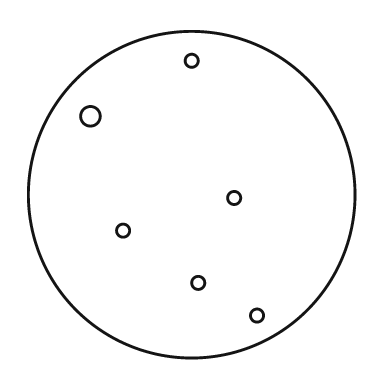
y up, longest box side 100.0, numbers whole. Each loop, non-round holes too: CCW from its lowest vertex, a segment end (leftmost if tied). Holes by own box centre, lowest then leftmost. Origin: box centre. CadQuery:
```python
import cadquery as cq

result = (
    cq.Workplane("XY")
    .moveTo(0.0, 0.0)
    .circle(50.0)
    .moveTo(20.0, -37.0)
    .circle(2.0)
    .moveTo(2.0, -27.0)
    .circle(2.0)
    .moveTo(-21.0, -11.0)
    .circle(2.0)
    .moveTo(13.0, -1.0)
    .circle(2.0)
    .moveTo(-31.0, 24.0)
    .circle(3.0)
    .moveTo(0.0, 41.0)
    .circle(2.0)
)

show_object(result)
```